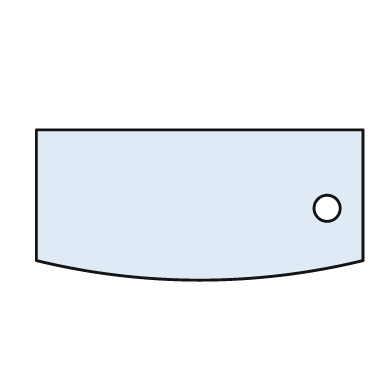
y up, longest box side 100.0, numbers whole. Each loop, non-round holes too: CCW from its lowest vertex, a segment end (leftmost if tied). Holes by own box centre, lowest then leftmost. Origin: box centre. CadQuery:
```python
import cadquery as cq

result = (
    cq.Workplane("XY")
    .moveTo(-50.0, -17.0)
    .threePointArc((0.0, -23.0), (50.0, -17.0))
    .lineTo(50.0, 23.0)
    .lineTo(-50.0, 23.0)
    .close()
    .moveTo(39.0, -1.0)
    .circle(4.0)
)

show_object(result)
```